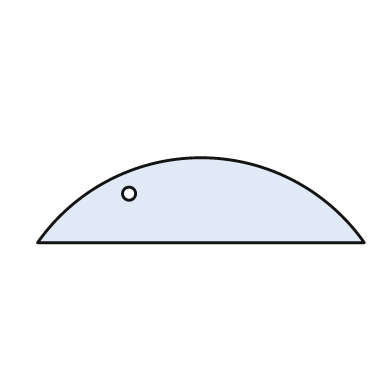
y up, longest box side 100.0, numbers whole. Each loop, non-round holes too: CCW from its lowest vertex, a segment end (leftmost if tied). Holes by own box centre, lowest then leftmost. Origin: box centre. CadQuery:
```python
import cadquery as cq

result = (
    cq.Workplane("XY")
    .moveTo(-50.0, -13.0)
    .lineTo(50.0, -13.0)
    .threePointArc((0.0, 13.0), (-50.0, -13.0))
    .close()
    .moveTo(-22.0, 2.0)
    .circle(2.0)
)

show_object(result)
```